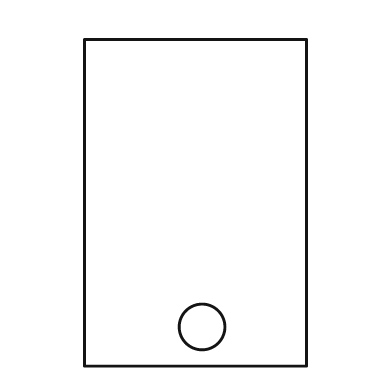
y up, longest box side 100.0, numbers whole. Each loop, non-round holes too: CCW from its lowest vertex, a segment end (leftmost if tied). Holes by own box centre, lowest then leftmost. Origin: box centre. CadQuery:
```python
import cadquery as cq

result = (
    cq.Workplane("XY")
    .moveTo(-34.0, -50.0)
    .lineTo(34.0, -50.0)
    .lineTo(34.0, 50.0)
    .lineTo(-34.0, 50.0)
    .close()
    .moveTo(2.0, -38.0)
    .circle(7.0)
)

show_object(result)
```